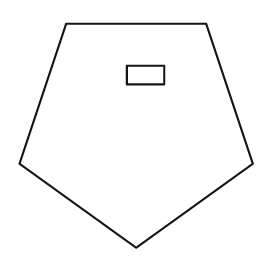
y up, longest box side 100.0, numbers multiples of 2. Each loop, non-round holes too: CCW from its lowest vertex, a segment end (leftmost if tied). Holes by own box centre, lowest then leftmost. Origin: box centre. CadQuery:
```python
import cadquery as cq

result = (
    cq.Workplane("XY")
    .moveTo(0.0, -48.0)
    .lineTo(50.0, -12.0)
    .lineTo(30.0, 48.0)
    .lineTo(-30.0, 48.0)
    .lineTo(-50.0, -12.0)
    .close()
    .moveTo(-4.0, 22.0)
    .lineTo(12.0, 22.0)
    .lineTo(12.0, 30.0)
    .lineTo(-4.0, 30.0)
    .close()
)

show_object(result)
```